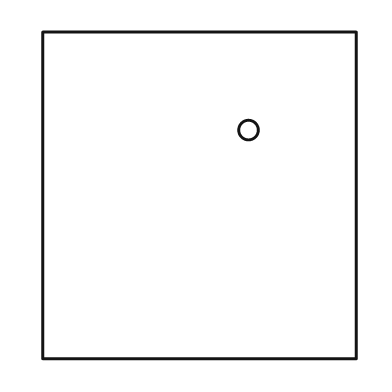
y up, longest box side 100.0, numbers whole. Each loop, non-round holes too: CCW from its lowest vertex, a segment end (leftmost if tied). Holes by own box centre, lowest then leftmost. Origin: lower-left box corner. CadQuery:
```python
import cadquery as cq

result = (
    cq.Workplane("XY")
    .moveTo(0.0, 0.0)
    .lineTo(96.0, 0.0)
    .lineTo(96.0, 100.0)
    .lineTo(0.0, 100.0)
    .close()
    .moveTo(63.0, 70.0)
    .circle(3.0)
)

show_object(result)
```